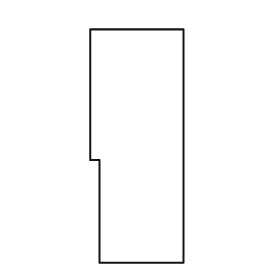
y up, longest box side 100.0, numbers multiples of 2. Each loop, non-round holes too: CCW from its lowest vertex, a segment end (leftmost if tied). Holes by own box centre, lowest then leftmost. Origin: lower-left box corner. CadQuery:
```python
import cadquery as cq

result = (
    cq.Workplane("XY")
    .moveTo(4.0, 0.0)
    .lineTo(40.0, 0.0)
    .lineTo(40.0, 100.0)
    .lineTo(0.0, 100.0)
    .lineTo(0.0, 44.0)
    .lineTo(4.0, 44.0)
    .close()
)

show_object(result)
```